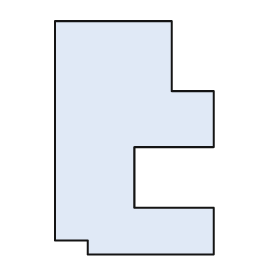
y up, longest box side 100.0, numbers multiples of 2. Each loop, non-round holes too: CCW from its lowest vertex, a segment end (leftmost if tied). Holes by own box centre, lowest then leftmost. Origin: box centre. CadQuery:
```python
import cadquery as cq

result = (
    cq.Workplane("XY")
    .moveTo(-20.0, -50.0)
    .lineTo(34.0, -50.0)
    .lineTo(34.0, -30.0)
    .lineTo(0.0, -30.0)
    .lineTo(0.0, -4.0)
    .lineTo(34.0, -4.0)
    .lineTo(34.0, 20.0)
    .lineTo(16.0, 20.0)
    .lineTo(16.0, 50.0)
    .lineTo(-34.0, 50.0)
    .lineTo(-34.0, -44.0)
    .lineTo(-20.0, -44.0)
    .close()
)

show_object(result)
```